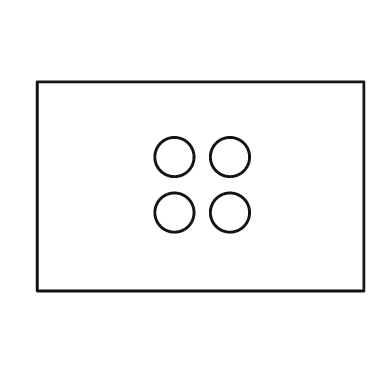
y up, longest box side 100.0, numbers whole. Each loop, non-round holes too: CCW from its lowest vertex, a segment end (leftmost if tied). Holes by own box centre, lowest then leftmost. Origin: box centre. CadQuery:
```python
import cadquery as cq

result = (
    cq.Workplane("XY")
    .moveTo(-50.0, -32.0)
    .lineTo(50.0, -32.0)
    .lineTo(50.0, 32.0)
    .lineTo(-50.0, 32.0)
    .close()
    .moveTo(-8.0, -8.0)
    .circle(6.0)
    .moveTo(9.0, -8.0)
    .circle(6.0)
    .moveTo(-8.0, 9.0)
    .circle(6.0)
    .moveTo(9.0, 9.0)
    .circle(6.0)
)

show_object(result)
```